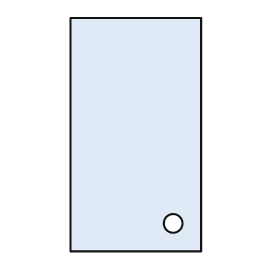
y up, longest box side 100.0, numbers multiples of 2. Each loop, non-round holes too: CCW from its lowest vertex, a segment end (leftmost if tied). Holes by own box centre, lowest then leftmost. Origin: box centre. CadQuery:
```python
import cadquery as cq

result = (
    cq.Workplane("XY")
    .moveTo(-28.0, -50.0)
    .lineTo(28.0, -50.0)
    .lineTo(28.0, 50.0)
    .lineTo(-28.0, 50.0)
    .close()
    .moveTo(16.0, -38.0)
    .circle(4.0)
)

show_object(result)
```